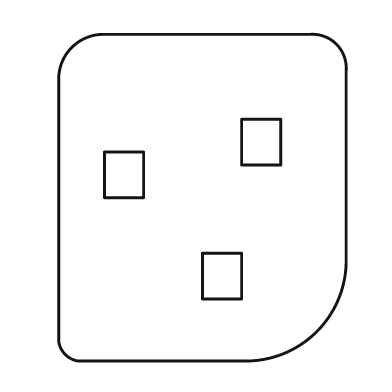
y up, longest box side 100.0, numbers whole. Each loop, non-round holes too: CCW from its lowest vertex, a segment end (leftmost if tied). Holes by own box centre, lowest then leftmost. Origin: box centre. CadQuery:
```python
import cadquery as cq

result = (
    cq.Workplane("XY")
    .moveTo(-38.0, -50.0)
    .lineTo(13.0, -50.0)
    .threePointArc((35.0, -41.0), (44.0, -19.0))
    .lineTo(44.0, 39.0)
    .threePointArc((41.0, 47.0), (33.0, 50.0))
    .lineTo(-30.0, 50.0)
    .threePointArc((-40.0, 46.0), (-44.0, 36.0))
    .lineTo(-44.0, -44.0)
    .threePointArc((-42.0, -48.0), (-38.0, -50.0))
    .close()
    .moveTo(0.0, -31.0)
    .lineTo(12.0, -31.0)
    .lineTo(12.0, -17.0)
    .lineTo(0.0, -17.0)
    .close()
    .moveTo(-30.0, 0.0)
    .lineTo(-18.0, 0.0)
    .lineTo(-18.0, 14.0)
    .lineTo(-30.0, 14.0)
    .close()
    .moveTo(12.0, 10.0)
    .lineTo(24.0, 10.0)
    .lineTo(24.0, 24.0)
    .lineTo(12.0, 24.0)
    .close()
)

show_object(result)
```